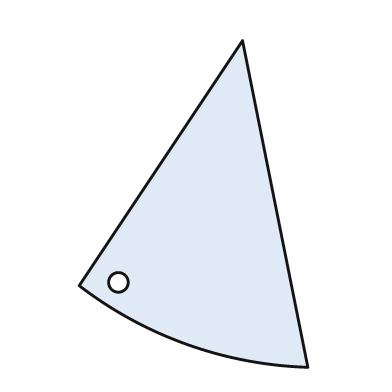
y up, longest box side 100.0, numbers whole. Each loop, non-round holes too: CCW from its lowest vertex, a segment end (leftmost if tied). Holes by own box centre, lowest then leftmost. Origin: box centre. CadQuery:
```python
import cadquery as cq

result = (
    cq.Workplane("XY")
    .moveTo(35.0, -50.0)
    .lineTo(15.0, 50.0)
    .lineTo(-35.0, -25.0)
    .threePointArc((-2.0, -43.0), (35.0, -50.0))
    .close()
    .moveTo(-23.0, -24.0)
    .circle(3.0)
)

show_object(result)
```